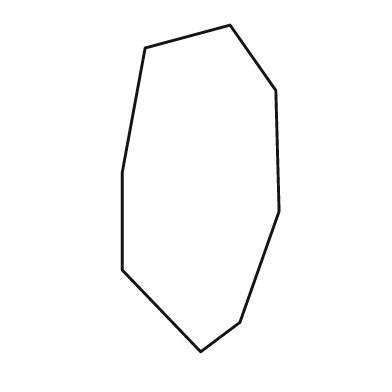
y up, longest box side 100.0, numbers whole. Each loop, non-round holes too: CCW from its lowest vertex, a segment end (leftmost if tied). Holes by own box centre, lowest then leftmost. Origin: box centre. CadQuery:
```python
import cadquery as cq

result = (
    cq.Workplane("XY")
    .moveTo(0.0, -50.0)
    .lineTo(12.0, -41.0)
    .lineTo(24.0, -7.0)
    .lineTo(23.0, 30.0)
    .lineTo(9.0, 50.0)
    .lineTo(-17.0, 43.0)
    .lineTo(-24.0, 5.0)
    .lineTo(-24.0, -25.0)
    .close()
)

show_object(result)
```